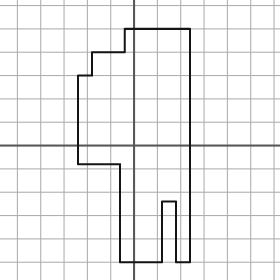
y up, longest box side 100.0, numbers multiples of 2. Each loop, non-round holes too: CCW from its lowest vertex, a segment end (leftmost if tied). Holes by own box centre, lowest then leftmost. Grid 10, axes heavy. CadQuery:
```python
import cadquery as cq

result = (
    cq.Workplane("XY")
    .moveTo(-6.0, -50.0)
    .lineTo(12.0, -50.0)
    .lineTo(12.0, -24.0)
    .lineTo(18.0, -24.0)
    .lineTo(18.0, -50.0)
    .lineTo(24.0, -50.0)
    .lineTo(24.0, 50.0)
    .lineTo(-4.0, 50.0)
    .lineTo(-4.0, 40.0)
    .lineTo(-18.0, 40.0)
    .lineTo(-18.0, 30.0)
    .lineTo(-24.0, 30.0)
    .lineTo(-24.0, -8.0)
    .lineTo(-6.0, -8.0)
    .close()
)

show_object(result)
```